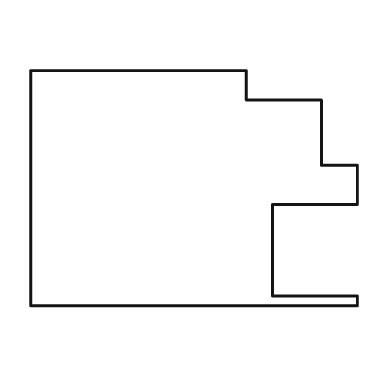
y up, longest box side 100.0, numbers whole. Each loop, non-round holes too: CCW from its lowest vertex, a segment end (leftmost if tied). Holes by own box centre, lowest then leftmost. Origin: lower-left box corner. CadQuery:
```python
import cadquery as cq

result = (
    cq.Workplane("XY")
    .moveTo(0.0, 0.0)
    .lineTo(100.0, 0.0)
    .lineTo(100.0, 3.0)
    .lineTo(74.0, 3.0)
    .lineTo(74.0, 31.0)
    .lineTo(100.0, 31.0)
    .lineTo(100.0, 43.0)
    .lineTo(89.0, 43.0)
    .lineTo(89.0, 63.0)
    .lineTo(66.0, 63.0)
    .lineTo(66.0, 72.0)
    .lineTo(0.0, 72.0)
    .close()
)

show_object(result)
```